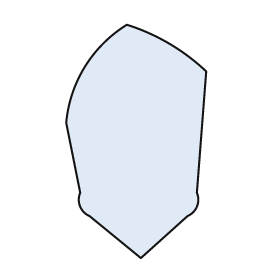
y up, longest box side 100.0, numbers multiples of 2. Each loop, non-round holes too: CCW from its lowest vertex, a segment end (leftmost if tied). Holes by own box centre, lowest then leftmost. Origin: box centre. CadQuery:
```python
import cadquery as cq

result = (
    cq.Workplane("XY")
    .moveTo(2.0, -50.0)
    .lineTo(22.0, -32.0)
    .threePointArc((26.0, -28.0), (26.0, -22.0))
    .lineTo(30.0, 30.0)
    .threePointArc((14.0, 42.0), (-4.0, 50.0))
    .threePointArc((-22.0, 32.0), (-30.0, 8.0))
    .lineTo(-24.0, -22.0)
    .threePointArc((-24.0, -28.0), (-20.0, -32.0))
    .close()
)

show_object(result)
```